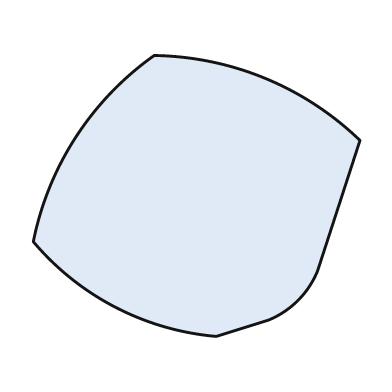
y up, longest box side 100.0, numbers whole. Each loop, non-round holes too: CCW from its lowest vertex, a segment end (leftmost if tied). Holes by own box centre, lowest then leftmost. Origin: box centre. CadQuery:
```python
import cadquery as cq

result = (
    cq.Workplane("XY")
    .moveTo(6.0, -43.0)
    .lineTo(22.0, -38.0)
    .threePointArc((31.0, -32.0), (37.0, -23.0))
    .lineTo(50.0, 17.0)
    .threePointArc((21.0, 36.0), (-13.0, 43.0))
    .threePointArc((-37.0, 18.0), (-50.0, -14.0))
    .threePointArc((-25.0, -34.0), (6.0, -43.0))
    .close()
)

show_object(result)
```